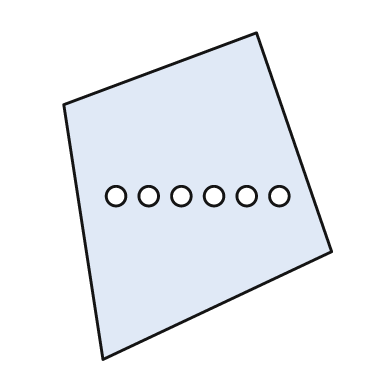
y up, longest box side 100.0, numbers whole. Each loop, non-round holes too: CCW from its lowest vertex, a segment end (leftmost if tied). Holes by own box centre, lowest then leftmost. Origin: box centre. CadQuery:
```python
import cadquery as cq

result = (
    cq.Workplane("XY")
    .moveTo(-29.0, -50.0)
    .lineTo(41.0, -17.0)
    .lineTo(18.0, 50.0)
    .lineTo(-41.0, 28.0)
    .close()
    .moveTo(-25.0, 0.0)
    .circle(3.0)
    .moveTo(-15.0, 0.0)
    .circle(3.0)
    .moveTo(-5.0, 0.0)
    .circle(3.0)
    .moveTo(5.0, 0.0)
    .circle(3.0)
    .moveTo(15.0, 0.0)
    .circle(3.0)
    .moveTo(25.0, 0.0)
    .circle(3.0)
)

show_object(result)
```